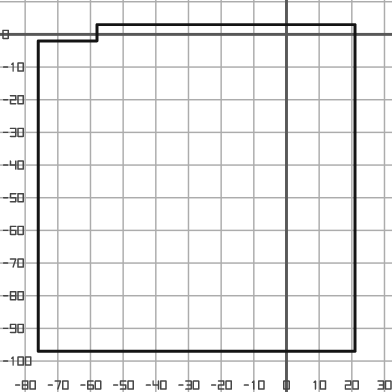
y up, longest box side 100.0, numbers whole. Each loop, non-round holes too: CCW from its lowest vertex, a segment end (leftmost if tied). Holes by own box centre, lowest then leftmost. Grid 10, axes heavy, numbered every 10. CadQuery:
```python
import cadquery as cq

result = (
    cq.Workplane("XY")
    .moveTo(-76.0, -97.0)
    .lineTo(21.0, -97.0)
    .lineTo(21.0, 3.0)
    .lineTo(-58.0, 3.0)
    .lineTo(-58.0, -2.0)
    .lineTo(-76.0, -2.0)
    .close()
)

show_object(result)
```